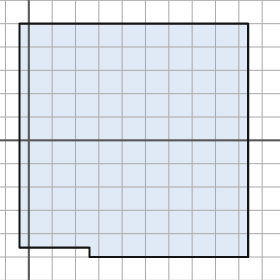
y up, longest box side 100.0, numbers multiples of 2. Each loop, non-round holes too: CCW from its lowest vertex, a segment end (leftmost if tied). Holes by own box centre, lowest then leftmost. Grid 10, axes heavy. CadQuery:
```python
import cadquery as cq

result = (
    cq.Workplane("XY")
    .moveTo(26.0, -50.0)
    .lineTo(94.0, -50.0)
    .lineTo(94.0, 50.0)
    .lineTo(-4.0, 50.0)
    .lineTo(-4.0, -46.0)
    .lineTo(26.0, -46.0)
    .close()
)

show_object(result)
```